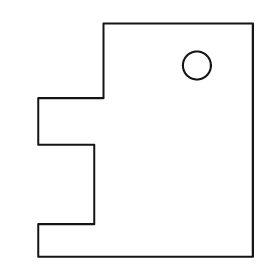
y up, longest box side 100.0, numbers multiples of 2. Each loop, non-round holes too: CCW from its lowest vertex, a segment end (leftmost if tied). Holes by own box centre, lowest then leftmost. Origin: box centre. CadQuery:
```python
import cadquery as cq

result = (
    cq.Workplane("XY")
    .moveTo(-46.0, -50.0)
    .lineTo(46.0, -50.0)
    .lineTo(46.0, 50.0)
    .lineTo(-18.0, 50.0)
    .lineTo(-18.0, 18.0)
    .lineTo(-46.0, 18.0)
    .lineTo(-46.0, -2.0)
    .lineTo(-22.0, -2.0)
    .lineTo(-22.0, -36.0)
    .lineTo(-46.0, -36.0)
    .close()
    .moveTo(22.0, 32.0)
    .circle(6.0)
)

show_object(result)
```